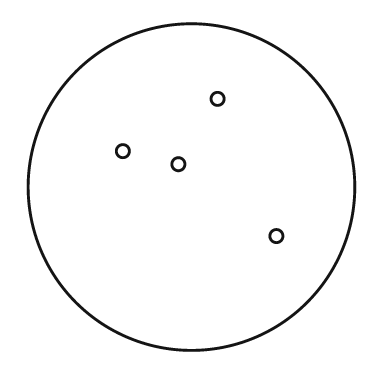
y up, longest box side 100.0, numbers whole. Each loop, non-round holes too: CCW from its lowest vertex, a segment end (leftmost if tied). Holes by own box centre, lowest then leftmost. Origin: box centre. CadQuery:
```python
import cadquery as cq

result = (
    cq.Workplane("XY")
    .moveTo(0.0, 0.0)
    .circle(50.0)
    .moveTo(26.0, -15.0)
    .circle(2.0)
    .moveTo(-4.0, 7.0)
    .circle(2.0)
    .moveTo(-21.0, 11.0)
    .circle(2.0)
    .moveTo(8.0, 27.0)
    .circle(2.0)
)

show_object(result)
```